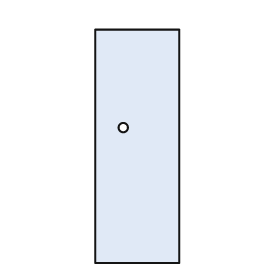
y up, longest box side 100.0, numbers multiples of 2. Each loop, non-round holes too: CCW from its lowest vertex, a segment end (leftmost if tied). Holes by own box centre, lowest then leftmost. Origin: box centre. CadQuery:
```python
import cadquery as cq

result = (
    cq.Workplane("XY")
    .moveTo(-18.0, -50.0)
    .lineTo(18.0, -50.0)
    .lineTo(18.0, 50.0)
    .lineTo(-18.0, 50.0)
    .close()
    .moveTo(-6.0, 8.0)
    .circle(2.0)
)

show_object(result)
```